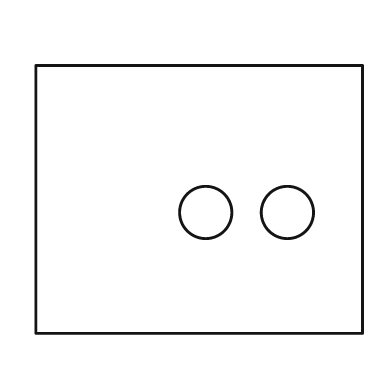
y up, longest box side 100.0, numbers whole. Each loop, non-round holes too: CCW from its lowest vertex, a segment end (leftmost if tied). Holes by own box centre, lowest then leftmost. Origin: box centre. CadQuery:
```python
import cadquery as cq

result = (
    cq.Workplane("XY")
    .moveTo(-50.0, -41.0)
    .lineTo(50.0, -41.0)
    .lineTo(50.0, 41.0)
    .lineTo(-50.0, 41.0)
    .close()
    .moveTo(2.0, -4.0)
    .circle(8.0)
    .moveTo(27.0, -4.0)
    .circle(8.0)
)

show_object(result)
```